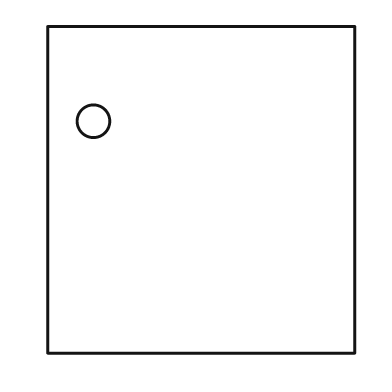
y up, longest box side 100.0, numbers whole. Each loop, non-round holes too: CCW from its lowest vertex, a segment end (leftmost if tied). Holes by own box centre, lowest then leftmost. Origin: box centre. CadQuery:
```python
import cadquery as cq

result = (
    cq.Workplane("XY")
    .moveTo(-47.0, -50.0)
    .lineTo(47.0, -50.0)
    .lineTo(47.0, 50.0)
    .lineTo(-47.0, 50.0)
    .close()
    .moveTo(-33.0, 21.0)
    .circle(5.0)
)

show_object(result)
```